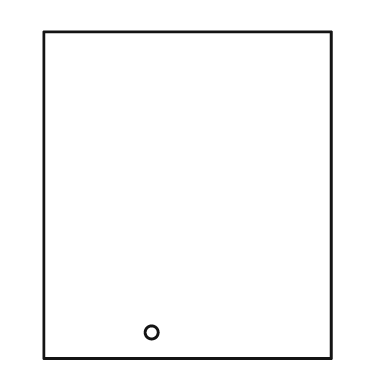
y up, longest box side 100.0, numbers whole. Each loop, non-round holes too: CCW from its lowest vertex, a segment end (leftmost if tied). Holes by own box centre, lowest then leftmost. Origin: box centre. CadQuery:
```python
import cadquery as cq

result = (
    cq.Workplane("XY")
    .moveTo(-44.0, -50.0)
    .lineTo(44.0, -50.0)
    .lineTo(44.0, 50.0)
    .lineTo(-44.0, 50.0)
    .close()
    .moveTo(-11.0, -42.0)
    .circle(2.0)
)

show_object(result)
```